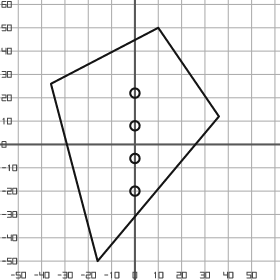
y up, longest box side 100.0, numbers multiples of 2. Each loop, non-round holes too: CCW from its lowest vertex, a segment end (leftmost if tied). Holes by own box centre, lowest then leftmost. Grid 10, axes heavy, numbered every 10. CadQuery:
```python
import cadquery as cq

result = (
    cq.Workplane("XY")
    .moveTo(-16.0, -50.0)
    .lineTo(36.0, 12.0)
    .lineTo(10.0, 50.0)
    .lineTo(-36.0, 26.0)
    .close()
    .moveTo(0.0, -20.0)
    .circle(2.0)
    .moveTo(0.0, -6.0)
    .circle(2.0)
    .moveTo(0.0, 8.0)
    .circle(2.0)
    .moveTo(0.0, 22.0)
    .circle(2.0)
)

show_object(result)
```